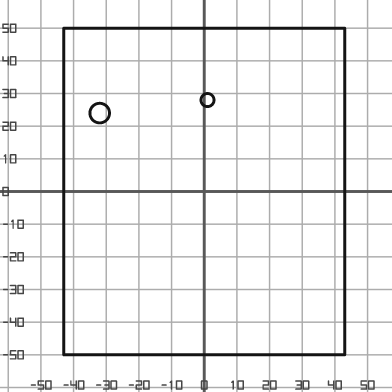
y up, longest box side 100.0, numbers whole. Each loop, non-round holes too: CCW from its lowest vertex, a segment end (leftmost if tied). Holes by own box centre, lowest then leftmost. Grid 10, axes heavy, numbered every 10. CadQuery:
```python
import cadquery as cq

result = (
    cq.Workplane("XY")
    .moveTo(-43.0, -50.0)
    .lineTo(43.0, -50.0)
    .lineTo(43.0, 50.0)
    .lineTo(-43.0, 50.0)
    .close()
    .moveTo(-32.0, 24.0)
    .circle(3.0)
    .moveTo(1.0, 28.0)
    .circle(2.0)
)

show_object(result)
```